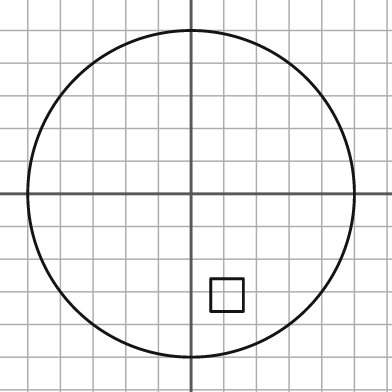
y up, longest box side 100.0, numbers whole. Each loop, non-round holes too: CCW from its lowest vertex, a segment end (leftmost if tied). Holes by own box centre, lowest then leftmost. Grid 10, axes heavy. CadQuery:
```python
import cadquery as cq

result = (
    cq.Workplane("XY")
    .moveTo(0.0, 0.0)
    .circle(50.0)
    .moveTo(6.0, -36.0)
    .lineTo(16.0, -36.0)
    .lineTo(16.0, -26.0)
    .lineTo(6.0, -26.0)
    .close()
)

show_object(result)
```